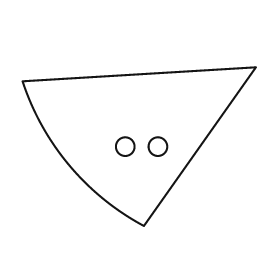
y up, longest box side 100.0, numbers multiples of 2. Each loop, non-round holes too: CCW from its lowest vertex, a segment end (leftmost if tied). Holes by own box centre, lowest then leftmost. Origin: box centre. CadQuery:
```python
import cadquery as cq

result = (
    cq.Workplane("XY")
    .moveTo(2.0, -34.0)
    .lineTo(50.0, 34.0)
    .lineTo(-50.0, 28.0)
    .threePointArc((-30.0, -8.0), (2.0, -34.0))
    .close()
    .moveTo(-6.0, 0.0)
    .circle(4.0)
    .moveTo(8.0, 0.0)
    .circle(4.0)
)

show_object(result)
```